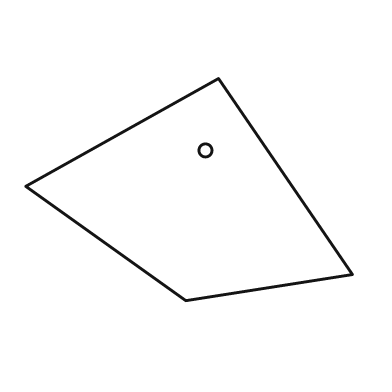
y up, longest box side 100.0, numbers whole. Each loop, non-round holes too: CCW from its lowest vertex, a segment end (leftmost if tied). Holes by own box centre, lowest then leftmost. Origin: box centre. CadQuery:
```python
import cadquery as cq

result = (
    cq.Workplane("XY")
    .moveTo(-1.0, -34.0)
    .lineTo(50.0, -26.0)
    .lineTo(9.0, 34.0)
    .lineTo(-50.0, 1.0)
    .close()
    .moveTo(5.0, 12.0)
    .circle(2.0)
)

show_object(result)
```